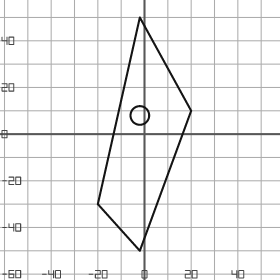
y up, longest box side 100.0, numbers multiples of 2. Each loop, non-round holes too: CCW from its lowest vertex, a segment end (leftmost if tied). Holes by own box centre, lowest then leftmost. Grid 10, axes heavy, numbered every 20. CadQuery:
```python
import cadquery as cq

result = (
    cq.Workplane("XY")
    .moveTo(-2.0, -50.0)
    .lineTo(20.0, 10.0)
    .lineTo(-2.0, 50.0)
    .lineTo(-20.0, -30.0)
    .close()
    .moveTo(-2.0, 8.0)
    .circle(4.0)
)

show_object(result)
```